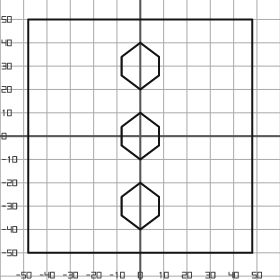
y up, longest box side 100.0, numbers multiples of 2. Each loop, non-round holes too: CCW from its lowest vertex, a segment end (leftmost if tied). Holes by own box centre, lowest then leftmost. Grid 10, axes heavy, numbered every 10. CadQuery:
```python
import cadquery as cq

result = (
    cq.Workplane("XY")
    .moveTo(-48.0, -50.0)
    .lineTo(48.0, -50.0)
    .lineTo(48.0, 50.0)
    .lineTo(-48.0, 50.0)
    .close()
    .moveTo(0.0, -40.0)
    .lineTo(8.0, -34.0)
    .lineTo(8.0, -26.0)
    .lineTo(0.0, -20.0)
    .lineTo(-8.0, -26.0)
    .lineTo(-8.0, -34.0)
    .close()
    .moveTo(0.0, -10.0)
    .lineTo(8.0, -4.0)
    .lineTo(8.0, 4.0)
    .lineTo(0.0, 10.0)
    .lineTo(-8.0, 4.0)
    .lineTo(-8.0, -4.0)
    .close()
    .moveTo(0.0, 20.0)
    .lineTo(8.0, 26.0)
    .lineTo(8.0, 34.0)
    .lineTo(0.0, 40.0)
    .lineTo(-8.0, 34.0)
    .lineTo(-8.0, 26.0)
    .close()
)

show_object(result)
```